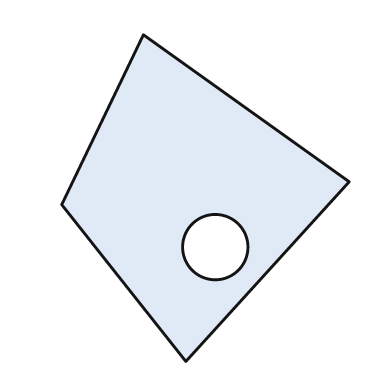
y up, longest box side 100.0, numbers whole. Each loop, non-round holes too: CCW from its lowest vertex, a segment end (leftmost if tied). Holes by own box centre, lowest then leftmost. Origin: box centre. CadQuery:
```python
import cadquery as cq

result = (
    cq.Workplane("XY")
    .moveTo(-6.0, -50.0)
    .lineTo(44.0, 5.0)
    .lineTo(-19.0, 50.0)
    .lineTo(-44.0, -2.0)
    .close()
    .moveTo(3.0, -15.0)
    .circle(10.0)
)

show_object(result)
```